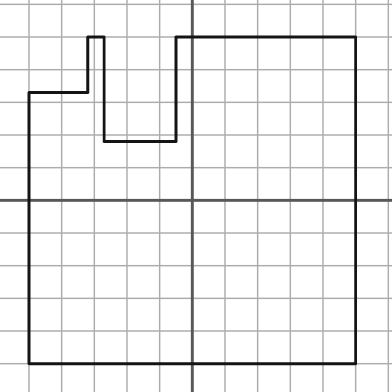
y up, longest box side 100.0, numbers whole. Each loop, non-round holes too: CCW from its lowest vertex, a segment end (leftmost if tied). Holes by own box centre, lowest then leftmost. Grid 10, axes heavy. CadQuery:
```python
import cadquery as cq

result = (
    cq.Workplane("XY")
    .moveTo(-50.0, -50.0)
    .lineTo(50.0, -50.0)
    .lineTo(50.0, 50.0)
    .lineTo(-5.0, 50.0)
    .lineTo(-5.0, 18.0)
    .lineTo(-27.0, 18.0)
    .lineTo(-27.0, 50.0)
    .lineTo(-32.0, 50.0)
    .lineTo(-32.0, 33.0)
    .lineTo(-50.0, 33.0)
    .close()
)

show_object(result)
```